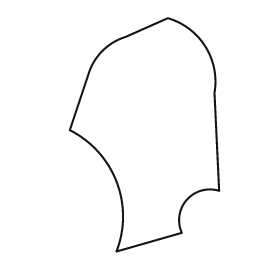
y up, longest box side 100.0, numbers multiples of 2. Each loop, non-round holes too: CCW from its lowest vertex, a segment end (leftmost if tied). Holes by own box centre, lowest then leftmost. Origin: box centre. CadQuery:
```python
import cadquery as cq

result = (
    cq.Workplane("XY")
    .moveTo(-12.0, -50.0)
    .lineTo(16.0, -42.0)
    .threePointArc((18.0, -28.0), (32.0, -24.0))
    .lineTo(30.0, 18.0)
    .threePointArc((26.0, 38.0), (10.0, 50.0))
    .lineTo(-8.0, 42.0)
    .threePointArc((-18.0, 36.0), (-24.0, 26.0))
    .lineTo(-32.0, 2.0)
    .threePointArc((-12.0, -20.0), (-12.0, -50.0))
    .close()
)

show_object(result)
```